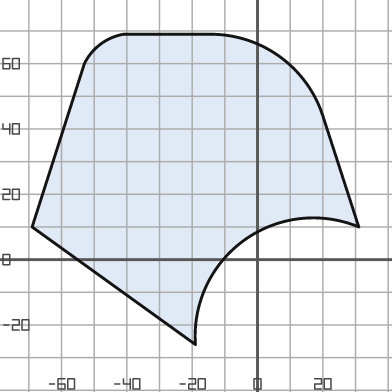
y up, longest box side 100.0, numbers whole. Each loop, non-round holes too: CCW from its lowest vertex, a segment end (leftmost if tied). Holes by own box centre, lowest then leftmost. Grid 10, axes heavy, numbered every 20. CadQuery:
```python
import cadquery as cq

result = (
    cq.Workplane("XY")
    .moveTo(-19.0, -26.0)
    .threePointArc((-4.0, 6.0), (31.0, 10.0))
    .lineTo(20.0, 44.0)
    .threePointArc((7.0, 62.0), (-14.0, 69.0))
    .lineTo(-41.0, 69.0)
    .threePointArc((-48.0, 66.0), (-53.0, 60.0))
    .lineTo(-69.0, 10.0)
    .close()
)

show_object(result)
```